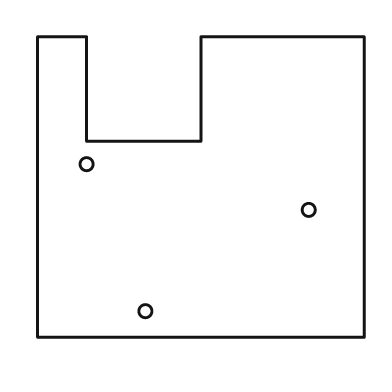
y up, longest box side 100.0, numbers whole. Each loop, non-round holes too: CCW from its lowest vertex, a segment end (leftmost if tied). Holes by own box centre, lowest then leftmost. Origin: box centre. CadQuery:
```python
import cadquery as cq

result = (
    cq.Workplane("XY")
    .moveTo(-50.0, -46.0)
    .lineTo(50.0, -46.0)
    .lineTo(50.0, 46.0)
    .lineTo(0.0, 46.0)
    .lineTo(0.0, 14.0)
    .lineTo(-35.0, 14.0)
    .lineTo(-35.0, 46.0)
    .lineTo(-50.0, 46.0)
    .close()
    .moveTo(-17.0, -38.0)
    .circle(2.0)
    .moveTo(33.0, -7.0)
    .circle(2.0)
    .moveTo(-35.0, 7.0)
    .circle(2.0)
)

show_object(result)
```